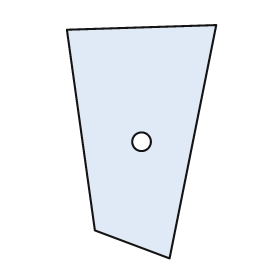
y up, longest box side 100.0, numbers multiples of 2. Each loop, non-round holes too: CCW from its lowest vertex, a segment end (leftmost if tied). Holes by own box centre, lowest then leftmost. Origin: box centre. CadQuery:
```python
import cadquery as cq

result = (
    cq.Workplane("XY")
    .moveTo(12.0, -50.0)
    .lineTo(32.0, 50.0)
    .lineTo(-32.0, 48.0)
    .lineTo(-20.0, -38.0)
    .close()
    .moveTo(0.0, 0.0)
    .circle(4.0)
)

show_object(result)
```